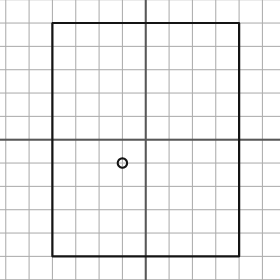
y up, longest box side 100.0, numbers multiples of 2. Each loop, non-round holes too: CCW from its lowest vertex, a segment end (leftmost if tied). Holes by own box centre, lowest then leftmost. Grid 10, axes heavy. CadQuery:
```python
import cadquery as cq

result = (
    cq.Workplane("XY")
    .moveTo(-40.0, -50.0)
    .lineTo(40.0, -50.0)
    .lineTo(40.0, 50.0)
    .lineTo(-40.0, 50.0)
    .close()
    .moveTo(-10.0, -10.0)
    .circle(2.0)
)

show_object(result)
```